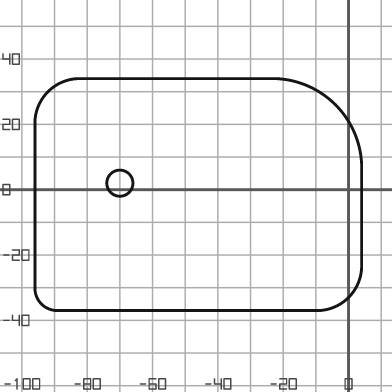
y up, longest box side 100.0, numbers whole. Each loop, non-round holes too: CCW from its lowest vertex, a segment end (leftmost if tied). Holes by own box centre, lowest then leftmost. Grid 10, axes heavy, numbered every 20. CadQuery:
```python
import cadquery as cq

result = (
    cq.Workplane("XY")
    .moveTo(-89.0, -37.0)
    .lineTo(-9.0, -37.0)
    .threePointArc((0.0, -33.0), (4.0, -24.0))
    .lineTo(4.0, 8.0)
    .threePointArc((-4.0, 26.0), (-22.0, 34.0))
    .lineTo(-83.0, 34.0)
    .threePointArc((-92.0, 30.0), (-96.0, 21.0))
    .lineTo(-96.0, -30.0)
    .threePointArc((-94.0, -35.0), (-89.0, -37.0))
    .close()
    .moveTo(-70.0, 2.0)
    .circle(4.0)
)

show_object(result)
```